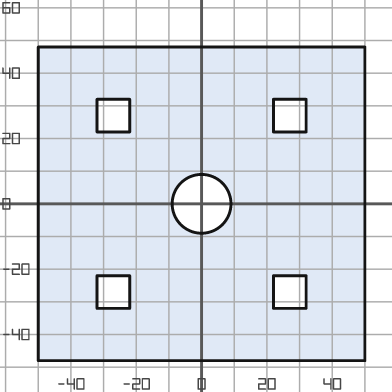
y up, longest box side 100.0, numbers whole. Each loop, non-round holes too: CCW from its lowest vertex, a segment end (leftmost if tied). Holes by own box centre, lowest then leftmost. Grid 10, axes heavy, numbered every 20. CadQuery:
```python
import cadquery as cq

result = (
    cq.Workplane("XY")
    .moveTo(-50.0, -48.0)
    .lineTo(50.0, -48.0)
    .lineTo(50.0, 48.0)
    .lineTo(-50.0, 48.0)
    .close()
    .moveTo(-32.0, -32.0)
    .lineTo(-22.0, -32.0)
    .lineTo(-22.0, -22.0)
    .lineTo(-32.0, -22.0)
    .close()
    .moveTo(22.0, -32.0)
    .lineTo(32.0, -32.0)
    .lineTo(32.0, -22.0)
    .lineTo(22.0, -22.0)
    .close()
    .moveTo(0.0, 0.0)
    .circle(9.0)
    .moveTo(-32.0, 22.0)
    .lineTo(-22.0, 22.0)
    .lineTo(-22.0, 32.0)
    .lineTo(-32.0, 32.0)
    .close()
    .moveTo(22.0, 22.0)
    .lineTo(32.0, 22.0)
    .lineTo(32.0, 32.0)
    .lineTo(22.0, 32.0)
    .close()
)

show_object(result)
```